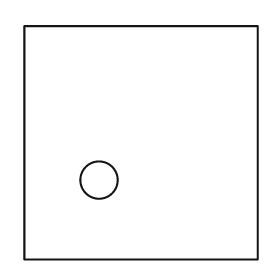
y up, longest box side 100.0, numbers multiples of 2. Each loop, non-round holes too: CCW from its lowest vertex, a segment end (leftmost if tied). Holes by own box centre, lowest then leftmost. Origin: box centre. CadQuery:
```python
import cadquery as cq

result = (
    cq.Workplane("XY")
    .moveTo(-50.0, -50.0)
    .lineTo(50.0, -50.0)
    .lineTo(50.0, 50.0)
    .lineTo(-50.0, 50.0)
    .close()
    .moveTo(-18.0, -16.0)
    .circle(8.0)
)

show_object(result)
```